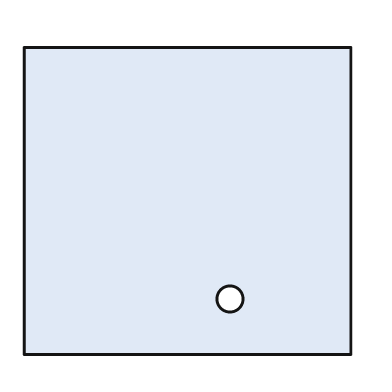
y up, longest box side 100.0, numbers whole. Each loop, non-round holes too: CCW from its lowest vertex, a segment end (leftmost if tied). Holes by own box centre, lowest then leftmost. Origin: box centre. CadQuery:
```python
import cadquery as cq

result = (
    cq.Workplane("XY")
    .moveTo(-50.0, -47.0)
    .lineTo(50.0, -47.0)
    .lineTo(50.0, 47.0)
    .lineTo(-50.0, 47.0)
    .close()
    .moveTo(13.0, -30.0)
    .circle(4.0)
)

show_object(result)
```